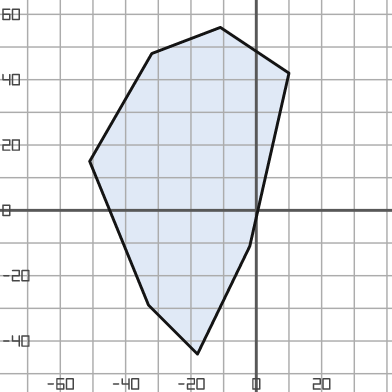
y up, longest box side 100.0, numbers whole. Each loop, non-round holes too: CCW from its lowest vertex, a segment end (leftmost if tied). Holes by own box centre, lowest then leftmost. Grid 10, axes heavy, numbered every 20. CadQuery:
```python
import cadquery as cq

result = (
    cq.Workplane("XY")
    .moveTo(-18.0, -44.0)
    .lineTo(-2.0, -11.0)
    .lineTo(10.0, 42.0)
    .lineTo(-11.0, 56.0)
    .lineTo(-32.0, 48.0)
    .lineTo(-51.0, 15.0)
    .lineTo(-33.0, -29.0)
    .close()
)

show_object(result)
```